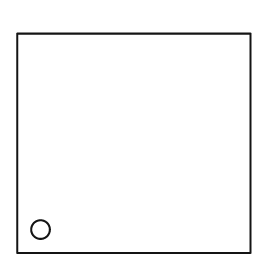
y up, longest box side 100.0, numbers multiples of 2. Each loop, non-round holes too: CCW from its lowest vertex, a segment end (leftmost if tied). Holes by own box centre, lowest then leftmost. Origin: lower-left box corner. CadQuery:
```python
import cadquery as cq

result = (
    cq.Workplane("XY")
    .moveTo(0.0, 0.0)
    .lineTo(100.0, 0.0)
    .lineTo(100.0, 94.0)
    .lineTo(0.0, 94.0)
    .close()
    .moveTo(10.0, 10.0)
    .circle(4.0)
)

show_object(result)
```